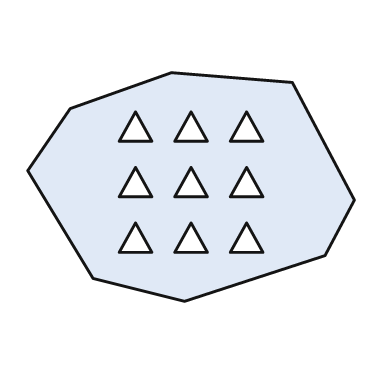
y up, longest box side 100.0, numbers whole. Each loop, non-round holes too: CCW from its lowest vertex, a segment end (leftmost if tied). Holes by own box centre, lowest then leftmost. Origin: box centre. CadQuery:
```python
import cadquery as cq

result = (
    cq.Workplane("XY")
    .moveTo(-2.0, -35.0)
    .lineTo(41.0, -21.0)
    .lineTo(50.0, -4.0)
    .lineTo(31.0, 32.0)
    .lineTo(-6.0, 35.0)
    .lineTo(-37.0, 24.0)
    .lineTo(-50.0, 5.0)
    .lineTo(-30.0, -28.0)
    .close()
    .moveTo(-22.0, -20.0)
    .lineTo(-12.0, -20.0)
    .lineTo(-17.0, -11.0)
    .close()
    .moveTo(-5.0, -20.0)
    .lineTo(5.0, -20.0)
    .lineTo(0.0, -11.0)
    .close()
    .moveTo(12.0, -20.0)
    .lineTo(22.0, -20.0)
    .lineTo(17.0, -11.0)
    .close()
    .moveTo(-22.0, -3.0)
    .lineTo(-12.0, -3.0)
    .lineTo(-17.0, 6.0)
    .close()
    .moveTo(-5.0, -3.0)
    .lineTo(5.0, -3.0)
    .lineTo(0.0, 6.0)
    .close()
    .moveTo(12.0, -3.0)
    .lineTo(22.0, -3.0)
    .lineTo(17.0, 6.0)
    .close()
    .moveTo(-22.0, 14.0)
    .lineTo(-12.0, 14.0)
    .lineTo(-17.0, 23.0)
    .close()
    .moveTo(-5.0, 14.0)
    .lineTo(5.0, 14.0)
    .lineTo(0.0, 23.0)
    .close()
    .moveTo(12.0, 14.0)
    .lineTo(22.0, 14.0)
    .lineTo(17.0, 23.0)
    .close()
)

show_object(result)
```